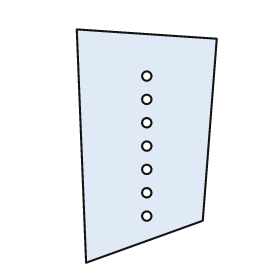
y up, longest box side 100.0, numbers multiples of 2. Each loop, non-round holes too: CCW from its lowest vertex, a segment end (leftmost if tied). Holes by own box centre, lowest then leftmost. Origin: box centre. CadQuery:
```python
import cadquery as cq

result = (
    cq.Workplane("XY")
    .moveTo(-26.0, -50.0)
    .lineTo(24.0, -32.0)
    .lineTo(30.0, 46.0)
    .lineTo(-30.0, 50.0)
    .close()
    .moveTo(0.0, -30.0)
    .circle(2.0)
    .moveTo(0.0, -20.0)
    .circle(2.0)
    .moveTo(0.0, -10.0)
    .circle(2.0)
    .moveTo(0.0, 0.0)
    .circle(2.0)
    .moveTo(0.0, 10.0)
    .circle(2.0)
    .moveTo(0.0, 20.0)
    .circle(2.0)
    .moveTo(0.0, 30.0)
    .circle(2.0)
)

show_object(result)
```